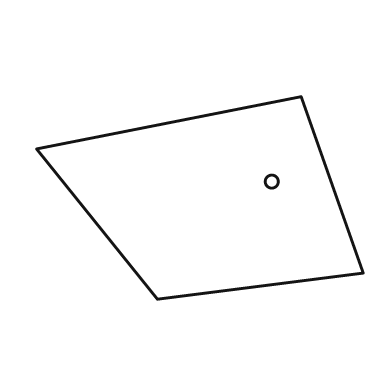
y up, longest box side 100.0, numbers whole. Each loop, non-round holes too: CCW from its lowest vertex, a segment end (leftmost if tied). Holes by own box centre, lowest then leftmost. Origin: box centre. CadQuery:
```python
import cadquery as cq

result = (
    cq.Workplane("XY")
    .moveTo(-13.0, -31.0)
    .lineTo(50.0, -23.0)
    .lineTo(31.0, 31.0)
    .lineTo(-50.0, 15.0)
    .close()
    .moveTo(22.0, 5.0)
    .circle(2.0)
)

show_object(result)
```